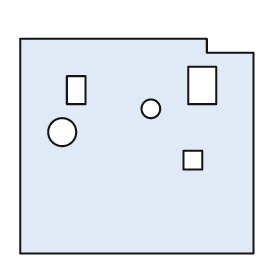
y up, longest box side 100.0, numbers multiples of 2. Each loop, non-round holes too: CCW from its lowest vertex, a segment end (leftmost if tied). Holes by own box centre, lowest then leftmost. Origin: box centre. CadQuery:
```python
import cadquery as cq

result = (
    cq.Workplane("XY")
    .moveTo(-50.0, -46.0)
    .lineTo(50.0, -46.0)
    .lineTo(50.0, 40.0)
    .lineTo(30.0, 40.0)
    .lineTo(30.0, 46.0)
    .lineTo(-50.0, 46.0)
    .close()
    .moveTo(20.0, -10.0)
    .lineTo(28.0, -10.0)
    .lineTo(28.0, -2.0)
    .lineTo(20.0, -2.0)
    .close()
    .moveTo(-32.0, 6.0)
    .circle(6.0)
    .moveTo(6.0, 16.0)
    .circle(4.0)
    .moveTo(-30.0, 18.0)
    .lineTo(-22.0, 18.0)
    .lineTo(-22.0, 30.0)
    .lineTo(-30.0, 30.0)
    .close()
    .moveTo(22.0, 18.0)
    .lineTo(34.0, 18.0)
    .lineTo(34.0, 34.0)
    .lineTo(22.0, 34.0)
    .close()
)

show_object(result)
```